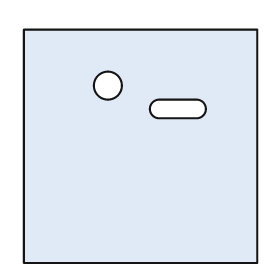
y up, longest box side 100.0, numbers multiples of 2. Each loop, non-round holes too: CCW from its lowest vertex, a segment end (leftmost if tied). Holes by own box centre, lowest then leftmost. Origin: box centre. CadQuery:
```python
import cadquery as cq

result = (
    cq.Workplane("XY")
    .moveTo(-50.0, -50.0)
    .lineTo(50.0, -50.0)
    .lineTo(50.0, 50.0)
    .lineTo(-50.0, 50.0)
    .close()
    .moveTo(8.0, 12.0)
    .lineTo(24.0, 12.0)
    .threePointArc((28.0, 16.0), (24.0, 20.0))
    .lineTo(8.0, 20.0)
    .threePointArc((4.0, 16.0), (8.0, 12.0))
    .close()
    .moveTo(-14.0, 26.0)
    .circle(6.0)
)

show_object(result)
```